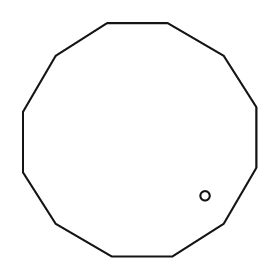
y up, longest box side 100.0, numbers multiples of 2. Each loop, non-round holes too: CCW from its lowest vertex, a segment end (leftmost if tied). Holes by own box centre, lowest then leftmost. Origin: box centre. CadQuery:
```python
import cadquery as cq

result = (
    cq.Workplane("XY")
    .moveTo(-12.0, -50.0)
    .lineTo(14.0, -50.0)
    .lineTo(36.0, -36.0)
    .lineTo(50.0, -12.0)
    .lineTo(50.0, 14.0)
    .lineTo(36.0, 36.0)
    .lineTo(12.0, 50.0)
    .lineTo(-14.0, 50.0)
    .lineTo(-36.0, 36.0)
    .lineTo(-50.0, 12.0)
    .lineTo(-50.0, -14.0)
    .lineTo(-36.0, -36.0)
    .close()
    .moveTo(28.0, -24.0)
    .circle(2.0)
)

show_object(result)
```